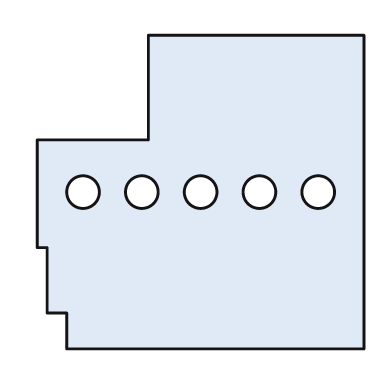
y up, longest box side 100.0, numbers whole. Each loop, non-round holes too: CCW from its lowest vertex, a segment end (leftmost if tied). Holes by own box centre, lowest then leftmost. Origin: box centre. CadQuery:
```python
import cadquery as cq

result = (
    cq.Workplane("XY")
    .moveTo(-41.0, -48.0)
    .lineTo(50.0, -48.0)
    .lineTo(50.0, 48.0)
    .lineTo(-16.0, 48.0)
    .lineTo(-16.0, 16.0)
    .lineTo(-50.0, 16.0)
    .lineTo(-50.0, -17.0)
    .lineTo(-47.0, -17.0)
    .lineTo(-47.0, -37.0)
    .lineTo(-41.0, -37.0)
    .close()
    .moveTo(-36.0, 0.0)
    .circle(5.0)
    .moveTo(-18.0, 0.0)
    .circle(5.0)
    .moveTo(0.0, 0.0)
    .circle(5.0)
    .moveTo(18.0, 0.0)
    .circle(5.0)
    .moveTo(36.0, 0.0)
    .circle(5.0)
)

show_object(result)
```